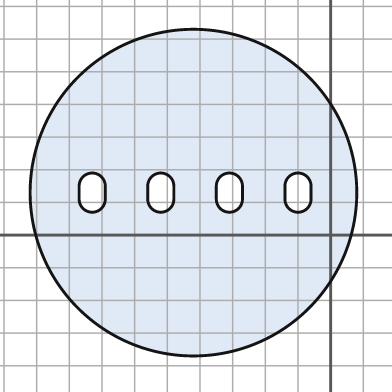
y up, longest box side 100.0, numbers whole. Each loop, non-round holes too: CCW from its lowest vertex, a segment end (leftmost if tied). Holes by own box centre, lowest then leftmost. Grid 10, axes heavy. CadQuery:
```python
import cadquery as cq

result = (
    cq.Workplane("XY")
    .moveTo(-42.0, 13.0)
    .circle(50.0)
    .moveTo(-77.0, 11.0)
    .threePointArc((-73.0, 7.0), (-69.0, 11.0))
    .lineTo(-69.0, 15.0)
    .threePointArc((-73.0, 19.0), (-77.0, 15.0))
    .close()
    .moveTo(-56.0, 11.0)
    .threePointArc((-52.0, 7.0), (-48.0, 11.0))
    .lineTo(-48.0, 15.0)
    .threePointArc((-52.0, 19.0), (-56.0, 15.0))
    .close()
    .moveTo(-35.0, 11.0)
    .threePointArc((-31.0, 7.0), (-27.0, 11.0))
    .lineTo(-27.0, 15.0)
    .threePointArc((-31.0, 19.0), (-35.0, 15.0))
    .close()
    .moveTo(-14.0, 11.0)
    .threePointArc((-10.0, 7.0), (-6.0, 11.0))
    .lineTo(-6.0, 15.0)
    .threePointArc((-10.0, 19.0), (-14.0, 15.0))
    .close()
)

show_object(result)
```